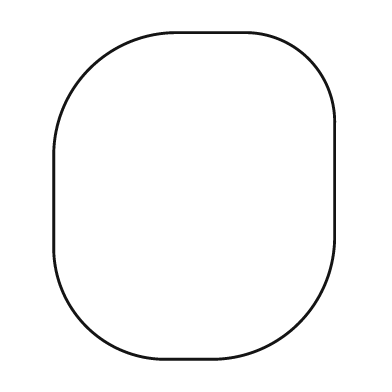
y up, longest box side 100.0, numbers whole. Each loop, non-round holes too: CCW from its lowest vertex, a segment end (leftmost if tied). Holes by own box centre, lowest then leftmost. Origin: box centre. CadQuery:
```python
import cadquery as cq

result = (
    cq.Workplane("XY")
    .moveTo(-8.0, -50.0)
    .lineTo(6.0, -50.0)
    .threePointArc((32.0, -39.0), (43.0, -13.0))
    .lineTo(43.0, 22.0)
    .threePointArc((35.0, 42.0), (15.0, 50.0))
    .lineTo(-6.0, 50.0)
    .threePointArc((-32.0, 39.0), (-43.0, 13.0))
    .lineTo(-43.0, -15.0)
    .threePointArc((-33.0, -40.0), (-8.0, -50.0))
    .close()
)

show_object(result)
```